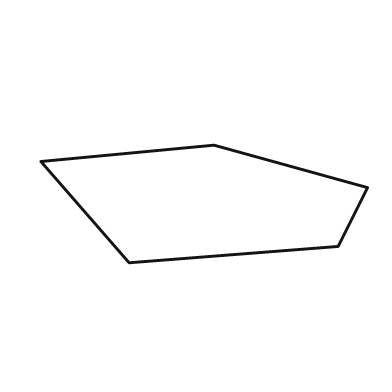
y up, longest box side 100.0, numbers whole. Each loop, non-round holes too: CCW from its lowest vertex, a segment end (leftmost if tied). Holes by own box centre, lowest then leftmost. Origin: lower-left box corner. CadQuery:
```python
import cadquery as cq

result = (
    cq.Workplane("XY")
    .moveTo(27.0, 0.0)
    .lineTo(91.0, 5.0)
    .lineTo(100.0, 23.0)
    .lineTo(53.0, 36.0)
    .lineTo(0.0, 31.0)
    .close()
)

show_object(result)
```